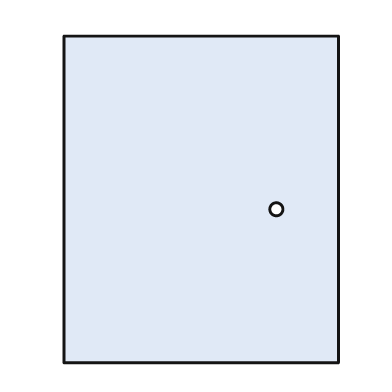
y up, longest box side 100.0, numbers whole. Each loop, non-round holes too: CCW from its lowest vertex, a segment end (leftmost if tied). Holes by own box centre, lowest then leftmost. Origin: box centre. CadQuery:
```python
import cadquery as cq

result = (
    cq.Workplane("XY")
    .moveTo(-42.0, -50.0)
    .lineTo(42.0, -50.0)
    .lineTo(42.0, 50.0)
    .lineTo(-42.0, 50.0)
    .close()
    .moveTo(23.0, -3.0)
    .circle(2.0)
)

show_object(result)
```